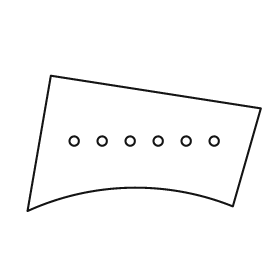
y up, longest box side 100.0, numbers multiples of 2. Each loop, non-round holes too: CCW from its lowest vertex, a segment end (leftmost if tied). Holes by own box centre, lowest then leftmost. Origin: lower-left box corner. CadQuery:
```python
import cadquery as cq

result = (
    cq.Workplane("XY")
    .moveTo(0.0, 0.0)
    .threePointArc((44.0, 10.0), (88.0, 2.0))
    .lineTo(100.0, 44.0)
    .lineTo(10.0, 58.0)
    .close()
    .moveTo(20.0, 30.0)
    .circle(2.0)
    .moveTo(32.0, 30.0)
    .circle(2.0)
    .moveTo(44.0, 30.0)
    .circle(2.0)
    .moveTo(56.0, 30.0)
    .circle(2.0)
    .moveTo(68.0, 30.0)
    .circle(2.0)
    .moveTo(80.0, 30.0)
    .circle(2.0)
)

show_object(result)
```